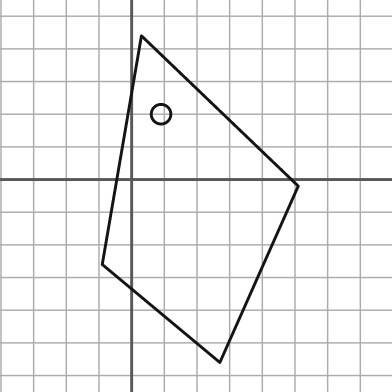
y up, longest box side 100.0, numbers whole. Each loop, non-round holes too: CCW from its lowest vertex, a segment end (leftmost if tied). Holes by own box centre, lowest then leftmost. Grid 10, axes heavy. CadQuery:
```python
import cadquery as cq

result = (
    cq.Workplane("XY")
    .moveTo(27.0, -56.0)
    .lineTo(51.0, -2.0)
    .lineTo(3.0, 44.0)
    .lineTo(-9.0, -26.0)
    .close()
    .moveTo(9.0, 20.0)
    .circle(3.0)
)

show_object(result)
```